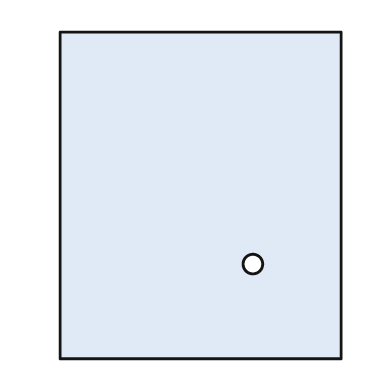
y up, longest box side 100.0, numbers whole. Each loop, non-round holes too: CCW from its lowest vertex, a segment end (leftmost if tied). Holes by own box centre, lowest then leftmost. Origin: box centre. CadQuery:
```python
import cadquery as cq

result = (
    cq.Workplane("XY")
    .moveTo(-43.0, -50.0)
    .lineTo(43.0, -50.0)
    .lineTo(43.0, 50.0)
    .lineTo(-43.0, 50.0)
    .close()
    .moveTo(16.0, -21.0)
    .circle(3.0)
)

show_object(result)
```